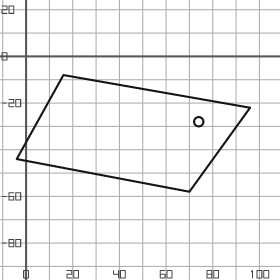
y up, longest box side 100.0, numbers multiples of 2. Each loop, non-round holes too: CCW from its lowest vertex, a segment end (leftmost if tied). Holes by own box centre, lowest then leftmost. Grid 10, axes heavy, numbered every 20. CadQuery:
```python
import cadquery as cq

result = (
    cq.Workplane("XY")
    .moveTo(70.0, -58.0)
    .lineTo(96.0, -22.0)
    .lineTo(16.0, -8.0)
    .lineTo(-4.0, -44.0)
    .close()
    .moveTo(74.0, -28.0)
    .circle(2.0)
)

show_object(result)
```